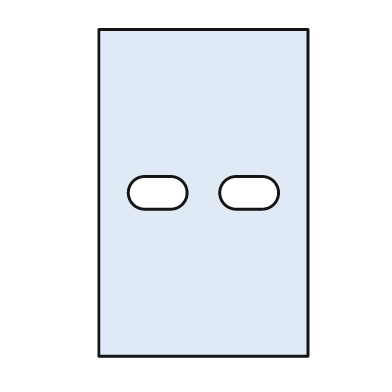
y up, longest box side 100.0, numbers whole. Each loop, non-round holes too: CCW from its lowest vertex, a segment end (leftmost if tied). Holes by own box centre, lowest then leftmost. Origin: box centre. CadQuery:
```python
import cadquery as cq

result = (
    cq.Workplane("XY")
    .moveTo(-32.0, -50.0)
    .lineTo(32.0, -50.0)
    .lineTo(32.0, 50.0)
    .lineTo(-32.0, 50.0)
    .close()
    .moveTo(-18.0, -5.0)
    .lineTo(-10.0, -5.0)
    .threePointArc((-5.0, 0.0), (-10.0, 5.0))
    .lineTo(-18.0, 5.0)
    .threePointArc((-23.0, 0.0), (-18.0, -5.0))
    .close()
    .moveTo(10.0, -5.0)
    .lineTo(18.0, -5.0)
    .threePointArc((23.0, 0.0), (18.0, 5.0))
    .lineTo(10.0, 5.0)
    .threePointArc((5.0, 0.0), (10.0, -5.0))
    .close()
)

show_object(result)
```